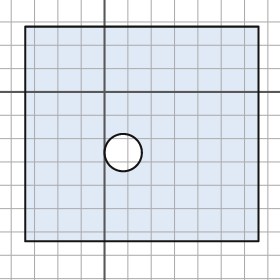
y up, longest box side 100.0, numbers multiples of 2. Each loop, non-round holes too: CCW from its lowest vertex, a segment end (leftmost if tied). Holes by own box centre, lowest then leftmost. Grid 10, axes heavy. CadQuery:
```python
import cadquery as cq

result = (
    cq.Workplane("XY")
    .moveTo(-34.0, -64.0)
    .lineTo(66.0, -64.0)
    .lineTo(66.0, 28.0)
    .lineTo(-34.0, 28.0)
    .close()
    .moveTo(8.0, -26.0)
    .circle(8.0)
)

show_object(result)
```